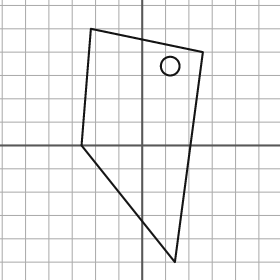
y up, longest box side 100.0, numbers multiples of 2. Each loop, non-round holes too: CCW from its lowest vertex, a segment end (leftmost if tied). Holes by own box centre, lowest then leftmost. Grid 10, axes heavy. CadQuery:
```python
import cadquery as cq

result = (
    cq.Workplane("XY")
    .moveTo(14.0, -50.0)
    .lineTo(26.0, 40.0)
    .lineTo(-22.0, 50.0)
    .lineTo(-26.0, 0.0)
    .close()
    .moveTo(12.0, 34.0)
    .circle(4.0)
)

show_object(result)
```